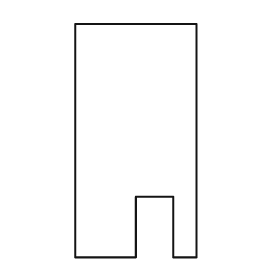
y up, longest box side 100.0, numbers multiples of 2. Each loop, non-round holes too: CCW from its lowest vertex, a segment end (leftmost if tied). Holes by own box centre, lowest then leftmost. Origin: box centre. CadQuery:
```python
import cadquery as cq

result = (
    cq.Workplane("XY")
    .moveTo(-26.0, -50.0)
    .lineTo(0.0, -50.0)
    .lineTo(0.0, -24.0)
    .lineTo(16.0, -24.0)
    .lineTo(16.0, -50.0)
    .lineTo(26.0, -50.0)
    .lineTo(26.0, 50.0)
    .lineTo(-26.0, 50.0)
    .close()
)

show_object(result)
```